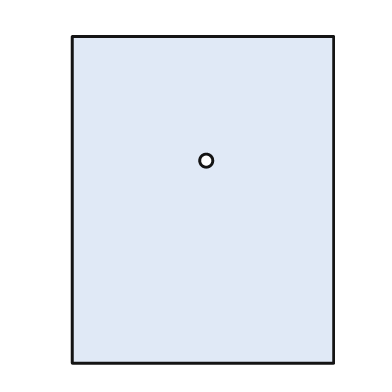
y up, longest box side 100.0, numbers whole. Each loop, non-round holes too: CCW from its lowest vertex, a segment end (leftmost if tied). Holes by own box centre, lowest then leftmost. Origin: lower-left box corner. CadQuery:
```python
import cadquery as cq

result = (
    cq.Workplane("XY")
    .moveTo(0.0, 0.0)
    .lineTo(80.0, 0.0)
    .lineTo(80.0, 100.0)
    .lineTo(0.0, 100.0)
    .close()
    .moveTo(41.0, 62.0)
    .circle(2.0)
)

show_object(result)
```